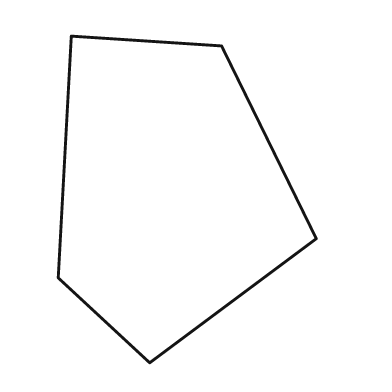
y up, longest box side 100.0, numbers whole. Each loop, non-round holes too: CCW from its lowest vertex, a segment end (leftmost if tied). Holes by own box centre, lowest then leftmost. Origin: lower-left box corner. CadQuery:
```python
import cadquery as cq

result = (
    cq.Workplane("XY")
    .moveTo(28.0, 0.0)
    .lineTo(79.0, 38.0)
    .lineTo(50.0, 97.0)
    .lineTo(4.0, 100.0)
    .lineTo(0.0, 26.0)
    .close()
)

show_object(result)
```